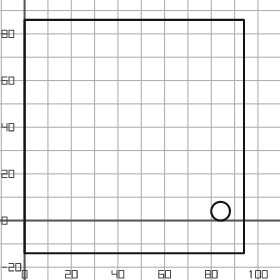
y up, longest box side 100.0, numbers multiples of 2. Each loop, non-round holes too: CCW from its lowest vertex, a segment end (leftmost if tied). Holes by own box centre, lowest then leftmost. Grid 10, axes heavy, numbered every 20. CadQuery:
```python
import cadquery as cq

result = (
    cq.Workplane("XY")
    .moveTo(0.0, -14.0)
    .lineTo(94.0, -14.0)
    .lineTo(94.0, 86.0)
    .lineTo(0.0, 86.0)
    .close()
    .moveTo(84.0, 4.0)
    .circle(4.0)
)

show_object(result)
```